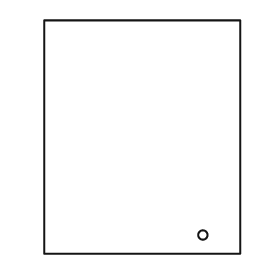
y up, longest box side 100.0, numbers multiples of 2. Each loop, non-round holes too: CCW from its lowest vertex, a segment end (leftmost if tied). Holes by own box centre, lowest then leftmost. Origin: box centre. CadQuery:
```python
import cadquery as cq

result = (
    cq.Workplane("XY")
    .moveTo(-42.0, -50.0)
    .lineTo(42.0, -50.0)
    .lineTo(42.0, 50.0)
    .lineTo(-42.0, 50.0)
    .close()
    .moveTo(26.0, -42.0)
    .circle(2.0)
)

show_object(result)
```